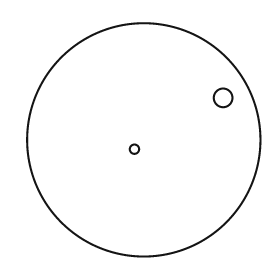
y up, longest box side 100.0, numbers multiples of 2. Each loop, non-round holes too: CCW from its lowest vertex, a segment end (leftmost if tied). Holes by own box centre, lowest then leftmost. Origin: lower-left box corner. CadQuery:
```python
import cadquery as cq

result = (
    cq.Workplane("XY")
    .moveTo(50.0, 50.0)
    .circle(50.0)
    .moveTo(46.0, 46.0)
    .circle(2.0)
    .moveTo(84.0, 68.0)
    .circle(4.0)
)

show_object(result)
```